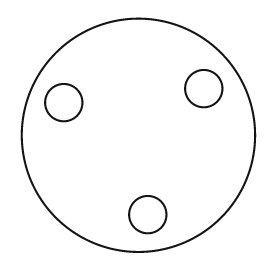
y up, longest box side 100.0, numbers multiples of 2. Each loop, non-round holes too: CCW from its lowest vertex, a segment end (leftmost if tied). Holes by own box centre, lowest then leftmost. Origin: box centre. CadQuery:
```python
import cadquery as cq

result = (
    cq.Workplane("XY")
    .moveTo(0.0, 0.0)
    .circle(50.0)
    .moveTo(4.0, -34.0)
    .circle(8.0)
    .moveTo(-32.0, 14.0)
    .circle(8.0)
    .moveTo(28.0, 20.0)
    .circle(8.0)
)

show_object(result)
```